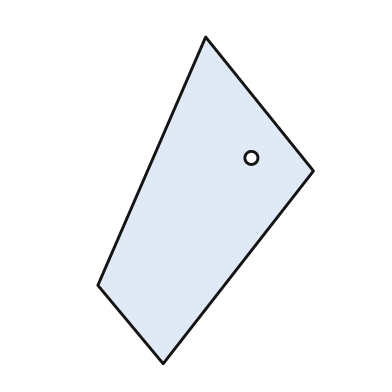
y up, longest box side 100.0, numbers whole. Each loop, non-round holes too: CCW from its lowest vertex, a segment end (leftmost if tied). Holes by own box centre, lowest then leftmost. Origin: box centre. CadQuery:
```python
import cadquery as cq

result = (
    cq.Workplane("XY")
    .moveTo(-13.0, -50.0)
    .lineTo(33.0, 9.0)
    .lineTo(0.0, 50.0)
    .lineTo(-33.0, -26.0)
    .close()
    .moveTo(14.0, 13.0)
    .circle(2.0)
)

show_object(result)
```